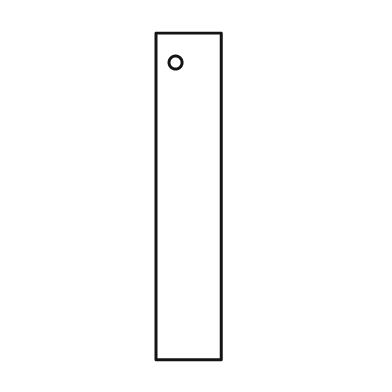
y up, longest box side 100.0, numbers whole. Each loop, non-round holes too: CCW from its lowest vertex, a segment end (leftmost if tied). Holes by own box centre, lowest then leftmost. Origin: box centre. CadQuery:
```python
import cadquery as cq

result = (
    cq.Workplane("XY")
    .moveTo(-10.0, -50.0)
    .lineTo(10.0, -50.0)
    .lineTo(10.0, 50.0)
    .lineTo(-10.0, 50.0)
    .close()
    .moveTo(-4.0, 41.0)
    .circle(2.0)
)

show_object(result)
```